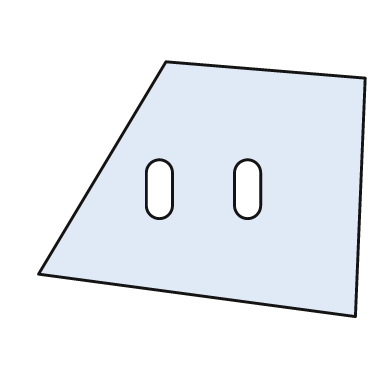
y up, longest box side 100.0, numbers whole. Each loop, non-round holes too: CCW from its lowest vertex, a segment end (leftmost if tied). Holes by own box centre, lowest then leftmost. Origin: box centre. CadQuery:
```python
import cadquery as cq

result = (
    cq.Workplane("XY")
    .moveTo(47.0, -39.0)
    .lineTo(50.0, 34.0)
    .lineTo(-11.0, 39.0)
    .lineTo(-50.0, -26.0)
    .close()
    .moveTo(-17.0, -5.0)
    .threePointArc((-13.0, -9.0), (-9.0, -5.0))
    .lineTo(-9.0, 5.0)
    .threePointArc((-13.0, 9.0), (-17.0, 5.0))
    .close()
    .moveTo(10.0, -5.0)
    .threePointArc((14.0, -9.0), (18.0, -5.0))
    .lineTo(18.0, 5.0)
    .threePointArc((14.0, 9.0), (10.0, 5.0))
    .close()
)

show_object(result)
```